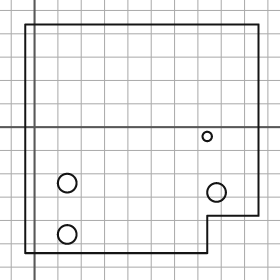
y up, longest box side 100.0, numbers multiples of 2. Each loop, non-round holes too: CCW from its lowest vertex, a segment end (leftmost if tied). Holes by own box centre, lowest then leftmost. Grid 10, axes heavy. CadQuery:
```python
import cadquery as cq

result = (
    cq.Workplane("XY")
    .moveTo(-4.0, -54.0)
    .lineTo(74.0, -54.0)
    .lineTo(74.0, -38.0)
    .lineTo(96.0, -38.0)
    .lineTo(96.0, 44.0)
    .lineTo(-4.0, 44.0)
    .close()
    .moveTo(14.0, -46.0)
    .circle(4.0)
    .moveTo(78.0, -28.0)
    .circle(4.0)
    .moveTo(14.0, -24.0)
    .circle(4.0)
    .moveTo(74.0, -4.0)
    .circle(2.0)
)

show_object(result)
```